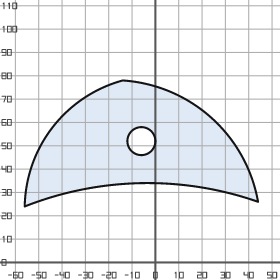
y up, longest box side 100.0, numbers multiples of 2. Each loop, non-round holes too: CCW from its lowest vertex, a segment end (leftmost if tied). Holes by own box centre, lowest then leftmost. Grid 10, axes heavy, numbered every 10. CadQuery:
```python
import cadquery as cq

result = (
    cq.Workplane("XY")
    .moveTo(-56.0, 24.0)
    .threePointArc((-6.0, 34.0), (44.0, 26.0))
    .threePointArc((24.0, 62.0), (-14.0, 78.0))
    .threePointArc((-44.0, 58.0), (-56.0, 24.0))
    .close()
    .moveTo(-6.0, 52.0)
    .circle(6.0)
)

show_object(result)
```